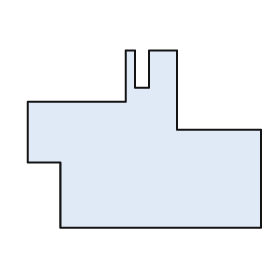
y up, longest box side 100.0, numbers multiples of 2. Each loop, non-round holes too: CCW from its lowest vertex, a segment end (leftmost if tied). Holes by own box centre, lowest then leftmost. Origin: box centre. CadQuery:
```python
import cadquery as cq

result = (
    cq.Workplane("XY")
    .moveTo(-36.0, -38.0)
    .lineTo(50.0, -38.0)
    .lineTo(50.0, 4.0)
    .lineTo(14.0, 4.0)
    .lineTo(14.0, 38.0)
    .lineTo(2.0, 38.0)
    .lineTo(2.0, 22.0)
    .lineTo(-4.0, 22.0)
    .lineTo(-4.0, 38.0)
    .lineTo(-8.0, 38.0)
    .lineTo(-8.0, 16.0)
    .lineTo(-50.0, 16.0)
    .lineTo(-50.0, -10.0)
    .lineTo(-36.0, -10.0)
    .close()
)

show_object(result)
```